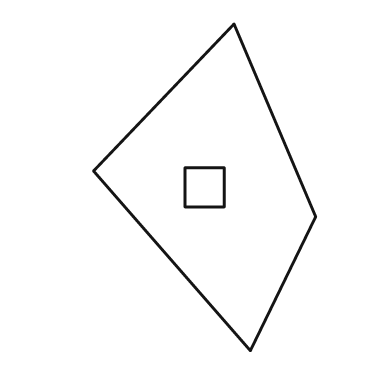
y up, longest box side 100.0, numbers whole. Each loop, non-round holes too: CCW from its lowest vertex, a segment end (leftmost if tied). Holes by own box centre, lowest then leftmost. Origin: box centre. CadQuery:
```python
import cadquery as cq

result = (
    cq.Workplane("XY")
    .moveTo(14.0, -50.0)
    .lineTo(34.0, -9.0)
    .lineTo(9.0, 50.0)
    .lineTo(-34.0, 5.0)
    .close()
    .moveTo(-6.0, -6.0)
    .lineTo(6.0, -6.0)
    .lineTo(6.0, 6.0)
    .lineTo(-6.0, 6.0)
    .close()
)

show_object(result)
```